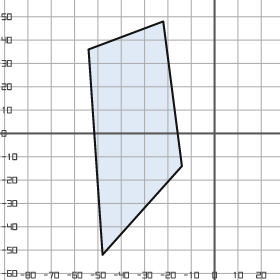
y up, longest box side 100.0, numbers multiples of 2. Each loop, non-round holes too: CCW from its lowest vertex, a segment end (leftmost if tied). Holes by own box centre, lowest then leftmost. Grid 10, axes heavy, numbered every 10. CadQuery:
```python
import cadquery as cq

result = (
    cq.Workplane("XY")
    .moveTo(-48.0, -52.0)
    .lineTo(-14.0, -14.0)
    .lineTo(-22.0, 48.0)
    .lineTo(-54.0, 36.0)
    .close()
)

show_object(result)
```